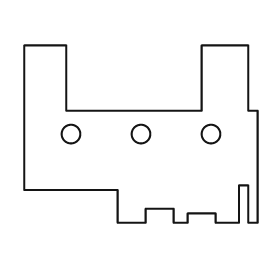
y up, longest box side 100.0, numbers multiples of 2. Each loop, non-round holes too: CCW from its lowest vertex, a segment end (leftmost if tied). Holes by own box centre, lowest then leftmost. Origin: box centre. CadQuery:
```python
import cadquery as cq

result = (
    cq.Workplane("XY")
    .moveTo(-10.0, -38.0)
    .lineTo(2.0, -38.0)
    .lineTo(2.0, -32.0)
    .lineTo(14.0, -32.0)
    .lineTo(14.0, -38.0)
    .lineTo(20.0, -38.0)
    .lineTo(20.0, -34.0)
    .lineTo(32.0, -34.0)
    .lineTo(32.0, -38.0)
    .lineTo(42.0, -38.0)
    .lineTo(42.0, -22.0)
    .lineTo(46.0, -22.0)
    .lineTo(46.0, -38.0)
    .lineTo(50.0, -38.0)
    .lineTo(50.0, 10.0)
    .lineTo(46.0, 10.0)
    .lineTo(46.0, 38.0)
    .lineTo(26.0, 38.0)
    .lineTo(26.0, 10.0)
    .lineTo(-32.0, 10.0)
    .lineTo(-32.0, 38.0)
    .lineTo(-50.0, 38.0)
    .lineTo(-50.0, -24.0)
    .lineTo(-10.0, -24.0)
    .close()
    .moveTo(-30.0, 0.0)
    .circle(4.0)
    .moveTo(0.0, 0.0)
    .circle(4.0)
    .moveTo(30.0, 0.0)
    .circle(4.0)
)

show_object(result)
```